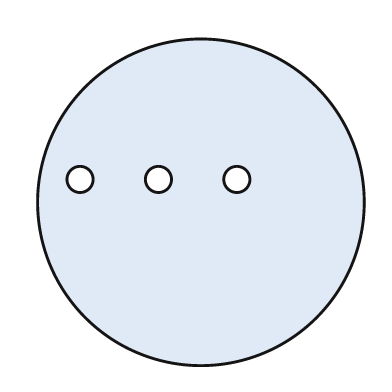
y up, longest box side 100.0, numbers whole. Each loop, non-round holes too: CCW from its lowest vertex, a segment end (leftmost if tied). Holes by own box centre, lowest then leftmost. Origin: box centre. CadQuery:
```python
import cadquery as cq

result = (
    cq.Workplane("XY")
    .moveTo(0.0, 0.0)
    .circle(50.0)
    .moveTo(-37.0, 7.0)
    .circle(4.0)
    .moveTo(-13.0, 7.0)
    .circle(4.0)
    .moveTo(11.0, 7.0)
    .circle(4.0)
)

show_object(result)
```